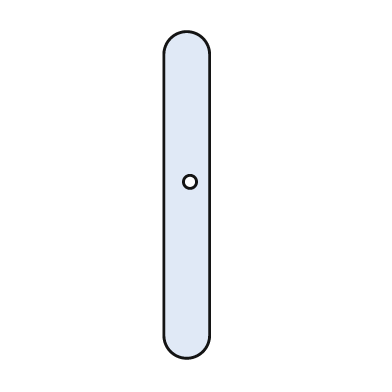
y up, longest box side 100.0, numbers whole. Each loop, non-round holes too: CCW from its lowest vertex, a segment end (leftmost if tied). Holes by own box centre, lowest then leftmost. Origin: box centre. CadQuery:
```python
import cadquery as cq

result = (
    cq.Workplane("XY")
    .moveTo(-7.0, -43.0)
    .threePointArc((0.0, -50.0), (7.0, -43.0))
    .lineTo(7.0, 43.0)
    .threePointArc((0.0, 50.0), (-7.0, 43.0))
    .close()
    .moveTo(1.0, 4.0)
    .circle(2.0)
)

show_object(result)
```